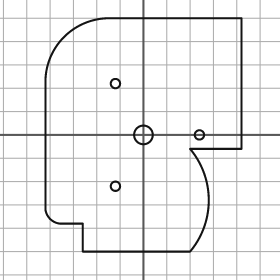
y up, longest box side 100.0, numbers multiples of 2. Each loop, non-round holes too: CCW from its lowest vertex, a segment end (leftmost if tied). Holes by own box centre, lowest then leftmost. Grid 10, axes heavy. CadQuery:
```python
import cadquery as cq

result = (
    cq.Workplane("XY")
    .moveTo(-26.0, -50.0)
    .lineTo(20.0, -50.0)
    .threePointArc((28.0, -28.0), (20.0, -6.0))
    .lineTo(42.0, -6.0)
    .lineTo(42.0, 50.0)
    .lineTo(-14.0, 50.0)
    .threePointArc((-34.0, 42.0), (-42.0, 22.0))
    .lineTo(-42.0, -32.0)
    .threePointArc((-40.0, -36.0), (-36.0, -38.0))
    .lineTo(-26.0, -38.0)
    .close()
    .moveTo(-12.0, -22.0)
    .circle(2.0)
    .moveTo(0.0, 0.0)
    .circle(4.0)
    .moveTo(24.0, 0.0)
    .circle(2.0)
    .moveTo(-12.0, 22.0)
    .circle(2.0)
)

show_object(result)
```